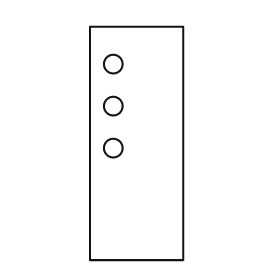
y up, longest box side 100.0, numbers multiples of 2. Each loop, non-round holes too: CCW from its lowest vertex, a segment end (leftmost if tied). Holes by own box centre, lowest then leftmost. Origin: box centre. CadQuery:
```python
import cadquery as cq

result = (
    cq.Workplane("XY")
    .moveTo(-20.0, -50.0)
    .lineTo(20.0, -50.0)
    .lineTo(20.0, 50.0)
    .lineTo(-20.0, 50.0)
    .close()
    .moveTo(-10.0, -2.0)
    .circle(4.0)
    .moveTo(-10.0, 16.0)
    .circle(4.0)
    .moveTo(-10.0, 34.0)
    .circle(4.0)
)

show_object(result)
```